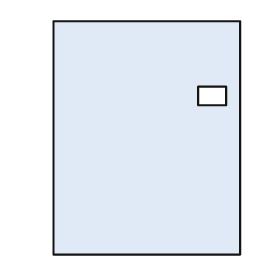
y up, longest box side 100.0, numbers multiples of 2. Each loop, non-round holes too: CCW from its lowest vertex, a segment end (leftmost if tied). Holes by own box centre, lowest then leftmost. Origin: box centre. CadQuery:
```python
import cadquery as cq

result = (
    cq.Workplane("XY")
    .moveTo(-40.0, -50.0)
    .lineTo(40.0, -50.0)
    .lineTo(40.0, 50.0)
    .lineTo(-40.0, 50.0)
    .close()
    .moveTo(22.0, 14.0)
    .lineTo(34.0, 14.0)
    .lineTo(34.0, 22.0)
    .lineTo(22.0, 22.0)
    .close()
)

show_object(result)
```